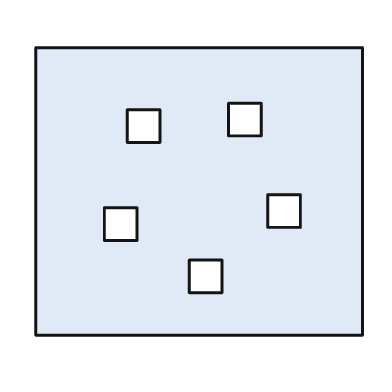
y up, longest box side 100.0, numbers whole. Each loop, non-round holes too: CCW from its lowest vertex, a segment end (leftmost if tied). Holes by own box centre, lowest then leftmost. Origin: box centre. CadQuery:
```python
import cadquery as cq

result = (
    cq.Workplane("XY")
    .moveTo(-50.0, -44.0)
    .lineTo(50.0, -44.0)
    .lineTo(50.0, 44.0)
    .lineTo(-50.0, 44.0)
    .close()
    .moveTo(-3.0, -31.0)
    .lineTo(7.0, -31.0)
    .lineTo(7.0, -21.0)
    .lineTo(-3.0, -21.0)
    .close()
    .moveTo(-29.0, -15.0)
    .lineTo(-19.0, -15.0)
    .lineTo(-19.0, -5.0)
    .lineTo(-29.0, -5.0)
    .close()
    .moveTo(21.0, -11.0)
    .lineTo(31.0, -11.0)
    .lineTo(31.0, -1.0)
    .lineTo(21.0, -1.0)
    .close()
    .moveTo(-22.0, 15.0)
    .lineTo(-12.0, 15.0)
    .lineTo(-12.0, 25.0)
    .lineTo(-22.0, 25.0)
    .close()
    .moveTo(9.0, 17.0)
    .lineTo(19.0, 17.0)
    .lineTo(19.0, 27.0)
    .lineTo(9.0, 27.0)
    .close()
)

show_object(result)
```